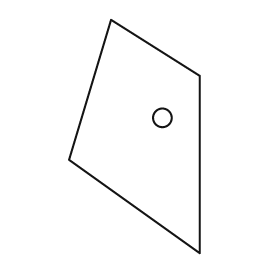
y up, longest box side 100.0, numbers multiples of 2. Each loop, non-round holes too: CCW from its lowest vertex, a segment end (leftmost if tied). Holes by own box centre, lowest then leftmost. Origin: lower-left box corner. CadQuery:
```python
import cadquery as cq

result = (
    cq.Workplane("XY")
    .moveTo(56.0, 0.0)
    .lineTo(56.0, 76.0)
    .lineTo(18.0, 100.0)
    .lineTo(0.0, 40.0)
    .close()
    .moveTo(40.0, 58.0)
    .circle(4.0)
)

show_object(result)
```